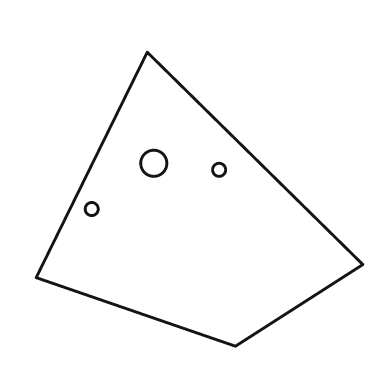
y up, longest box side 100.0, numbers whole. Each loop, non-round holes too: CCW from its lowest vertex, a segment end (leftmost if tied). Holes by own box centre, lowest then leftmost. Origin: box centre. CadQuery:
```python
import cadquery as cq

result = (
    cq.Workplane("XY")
    .moveTo(11.0, -45.0)
    .lineTo(50.0, -20.0)
    .lineTo(-16.0, 45.0)
    .lineTo(-50.0, -24.0)
    .close()
    .moveTo(-33.0, -3.0)
    .circle(2.0)
    .moveTo(6.0, 9.0)
    .circle(2.0)
    .moveTo(-14.0, 11.0)
    .circle(4.0)
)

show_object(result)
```